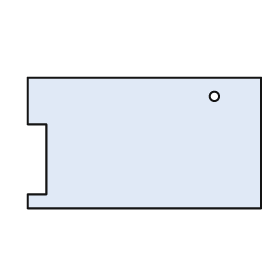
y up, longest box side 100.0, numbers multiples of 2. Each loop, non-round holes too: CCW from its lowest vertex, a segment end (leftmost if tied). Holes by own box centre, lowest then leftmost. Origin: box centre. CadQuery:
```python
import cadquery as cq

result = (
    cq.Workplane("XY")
    .moveTo(-50.0, -28.0)
    .lineTo(50.0, -28.0)
    .lineTo(50.0, 28.0)
    .lineTo(-50.0, 28.0)
    .lineTo(-50.0, 8.0)
    .lineTo(-42.0, 8.0)
    .lineTo(-42.0, -22.0)
    .lineTo(-50.0, -22.0)
    .close()
    .moveTo(30.0, 20.0)
    .circle(2.0)
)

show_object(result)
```